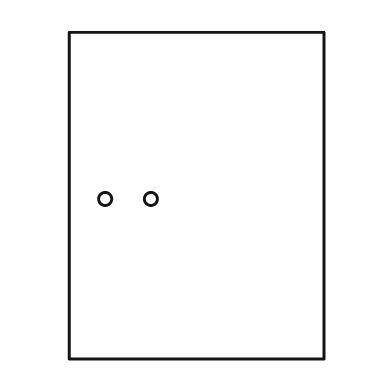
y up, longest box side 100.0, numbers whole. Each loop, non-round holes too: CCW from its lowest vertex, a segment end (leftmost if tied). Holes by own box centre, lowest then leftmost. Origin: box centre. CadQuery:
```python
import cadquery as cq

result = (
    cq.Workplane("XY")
    .moveTo(-39.0, -50.0)
    .lineTo(39.0, -50.0)
    .lineTo(39.0, 50.0)
    .lineTo(-39.0, 50.0)
    .close()
    .moveTo(-28.0, -1.0)
    .circle(2.0)
    .moveTo(-14.0, -1.0)
    .circle(2.0)
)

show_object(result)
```